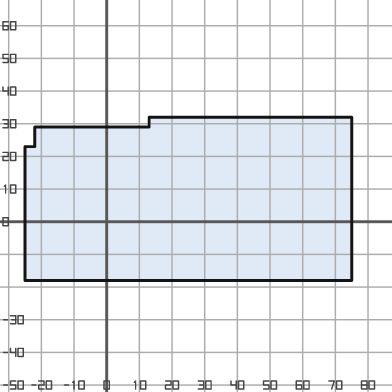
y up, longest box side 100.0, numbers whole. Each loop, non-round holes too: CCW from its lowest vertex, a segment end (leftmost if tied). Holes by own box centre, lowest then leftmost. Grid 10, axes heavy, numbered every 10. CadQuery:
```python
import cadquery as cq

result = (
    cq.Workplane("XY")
    .moveTo(-25.0, -18.0)
    .lineTo(75.0, -18.0)
    .lineTo(75.0, 32.0)
    .lineTo(13.0, 32.0)
    .lineTo(13.0, 29.0)
    .lineTo(-22.0, 29.0)
    .lineTo(-22.0, 23.0)
    .lineTo(-25.0, 23.0)
    .close()
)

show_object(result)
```